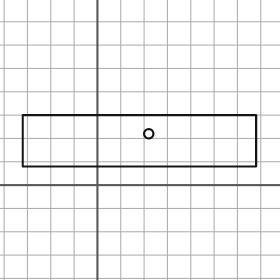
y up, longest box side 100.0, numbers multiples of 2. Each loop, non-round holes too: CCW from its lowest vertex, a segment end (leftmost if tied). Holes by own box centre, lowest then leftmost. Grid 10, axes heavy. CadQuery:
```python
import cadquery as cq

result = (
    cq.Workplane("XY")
    .moveTo(-32.0, 8.0)
    .lineTo(68.0, 8.0)
    .lineTo(68.0, 30.0)
    .lineTo(-32.0, 30.0)
    .close()
    .moveTo(22.0, 22.0)
    .circle(2.0)
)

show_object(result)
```